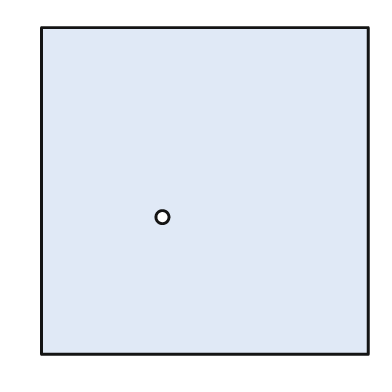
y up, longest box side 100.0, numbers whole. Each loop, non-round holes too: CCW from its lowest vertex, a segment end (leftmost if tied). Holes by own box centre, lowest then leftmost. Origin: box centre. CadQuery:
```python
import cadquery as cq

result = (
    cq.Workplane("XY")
    .moveTo(-50.0, -50.0)
    .lineTo(50.0, -50.0)
    .lineTo(50.0, 50.0)
    .lineTo(-50.0, 50.0)
    .close()
    .moveTo(-13.0, -8.0)
    .circle(2.0)
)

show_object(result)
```